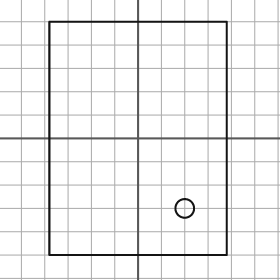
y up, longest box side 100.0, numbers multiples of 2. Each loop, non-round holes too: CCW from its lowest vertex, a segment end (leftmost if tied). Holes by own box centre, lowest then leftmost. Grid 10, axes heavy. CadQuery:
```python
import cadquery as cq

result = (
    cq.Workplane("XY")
    .moveTo(-38.0, -50.0)
    .lineTo(38.0, -50.0)
    .lineTo(38.0, 50.0)
    .lineTo(-38.0, 50.0)
    .close()
    .moveTo(20.0, -30.0)
    .circle(4.0)
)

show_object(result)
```